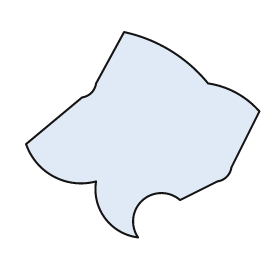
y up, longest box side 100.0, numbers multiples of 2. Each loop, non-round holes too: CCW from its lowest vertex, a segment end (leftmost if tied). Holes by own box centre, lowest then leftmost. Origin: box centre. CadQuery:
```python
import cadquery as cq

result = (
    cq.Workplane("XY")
    .moveTo(-2.0, -44.0)
    .threePointArc((0.0, -28.0), (16.0, -28.0))
    .lineTo(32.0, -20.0)
    .threePointArc((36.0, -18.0), (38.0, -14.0))
    .lineTo(50.0, 10.0)
    .threePointArc((40.0, 18.0), (28.0, 22.0))
    .threePointArc((12.0, 36.0), (-8.0, 44.0))
    .lineTo(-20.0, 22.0)
    .threePointArc((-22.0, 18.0), (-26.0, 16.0))
    .lineTo(-50.0, -4.0)
    .threePointArc((-38.0, -18.0), (-20.0, -20.0))
    .threePointArc((-16.0, -36.0), (-2.0, -44.0))
    .close()
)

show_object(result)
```